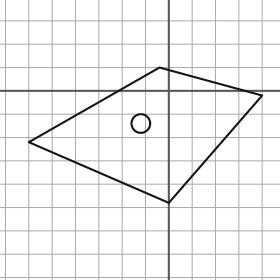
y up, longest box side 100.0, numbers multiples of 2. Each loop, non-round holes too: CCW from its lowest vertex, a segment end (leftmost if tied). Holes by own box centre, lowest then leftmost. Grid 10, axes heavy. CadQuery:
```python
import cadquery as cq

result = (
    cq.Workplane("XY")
    .moveTo(0.0, -48.0)
    .lineTo(40.0, -2.0)
    .lineTo(-4.0, 10.0)
    .lineTo(-60.0, -22.0)
    .close()
    .moveTo(-12.0, -14.0)
    .circle(4.0)
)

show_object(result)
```